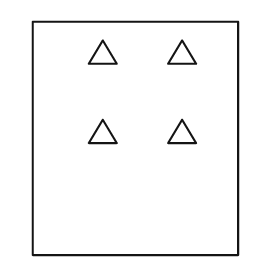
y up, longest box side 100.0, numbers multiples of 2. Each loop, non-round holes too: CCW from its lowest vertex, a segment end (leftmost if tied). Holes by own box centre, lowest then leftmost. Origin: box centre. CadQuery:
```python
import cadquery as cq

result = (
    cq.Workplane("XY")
    .moveTo(-44.0, -50.0)
    .lineTo(44.0, -50.0)
    .lineTo(44.0, 50.0)
    .lineTo(-44.0, 50.0)
    .close()
    .moveTo(-20.0, -2.0)
    .lineTo(-8.0, -2.0)
    .lineTo(-14.0, 8.0)
    .close()
    .moveTo(14.0, -2.0)
    .lineTo(26.0, -2.0)
    .lineTo(20.0, 8.0)
    .close()
    .moveTo(-20.0, 32.0)
    .lineTo(-8.0, 32.0)
    .lineTo(-14.0, 42.0)
    .close()
    .moveTo(14.0, 32.0)
    .lineTo(26.0, 32.0)
    .lineTo(20.0, 42.0)
    .close()
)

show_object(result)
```